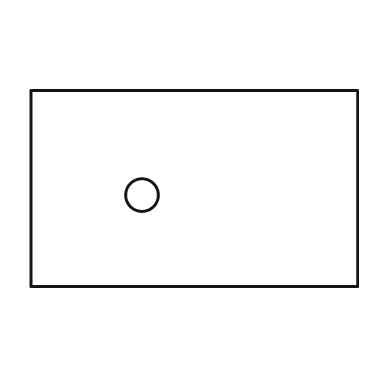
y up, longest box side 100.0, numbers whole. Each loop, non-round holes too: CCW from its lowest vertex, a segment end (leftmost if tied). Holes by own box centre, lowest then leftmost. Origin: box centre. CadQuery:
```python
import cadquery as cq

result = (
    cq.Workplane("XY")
    .moveTo(-50.0, -30.0)
    .lineTo(50.0, -30.0)
    .lineTo(50.0, 30.0)
    .lineTo(-50.0, 30.0)
    .close()
    .moveTo(-16.0, -2.0)
    .circle(5.0)
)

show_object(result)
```